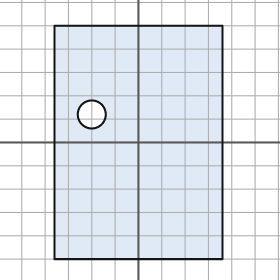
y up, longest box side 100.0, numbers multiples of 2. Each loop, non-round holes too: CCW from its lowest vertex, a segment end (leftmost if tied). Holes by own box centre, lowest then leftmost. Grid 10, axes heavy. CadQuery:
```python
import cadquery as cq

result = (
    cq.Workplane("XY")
    .moveTo(-36.0, -50.0)
    .lineTo(36.0, -50.0)
    .lineTo(36.0, 50.0)
    .lineTo(-36.0, 50.0)
    .close()
    .moveTo(-20.0, 12.0)
    .circle(6.0)
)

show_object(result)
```